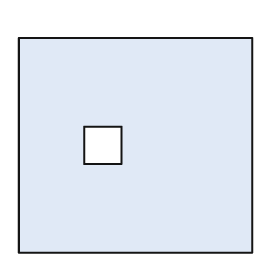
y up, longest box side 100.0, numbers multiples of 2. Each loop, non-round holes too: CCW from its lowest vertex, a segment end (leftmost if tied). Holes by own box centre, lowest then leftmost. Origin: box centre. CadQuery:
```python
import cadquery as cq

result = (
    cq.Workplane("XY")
    .moveTo(-50.0, -46.0)
    .lineTo(50.0, -46.0)
    .lineTo(50.0, 46.0)
    .lineTo(-50.0, 46.0)
    .close()
    .moveTo(-22.0, -8.0)
    .lineTo(-6.0, -8.0)
    .lineTo(-6.0, 8.0)
    .lineTo(-22.0, 8.0)
    .close()
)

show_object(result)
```